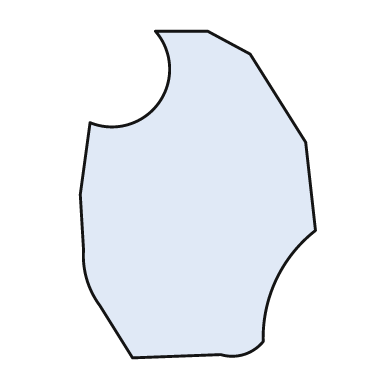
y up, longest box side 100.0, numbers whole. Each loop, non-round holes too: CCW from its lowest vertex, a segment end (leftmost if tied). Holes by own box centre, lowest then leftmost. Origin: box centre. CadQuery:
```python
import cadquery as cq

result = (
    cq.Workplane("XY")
    .moveTo(-20.0, -50.0)
    .lineTo(7.0, -49.0)
    .threePointArc((14.0, -49.0), (20.0, -45.0))
    .threePointArc((24.0, -26.0), (36.0, -11.0))
    .lineTo(33.0, 16.0)
    .lineTo(16.0, 43.0)
    .lineTo(3.0, 50.0)
    .lineTo(-13.0, 50.0)
    .threePointArc((-12.0, 28.0), (-33.0, 22.0))
    .lineTo(-36.0, 0.0)
    .lineTo(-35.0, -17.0)
    .threePointArc((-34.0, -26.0), (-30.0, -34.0))
    .close()
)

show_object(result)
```